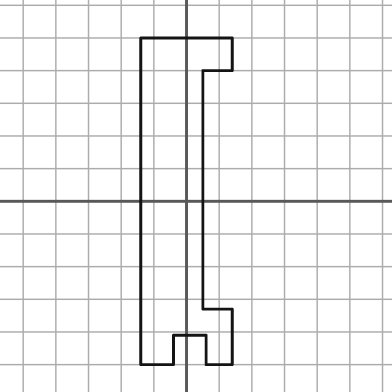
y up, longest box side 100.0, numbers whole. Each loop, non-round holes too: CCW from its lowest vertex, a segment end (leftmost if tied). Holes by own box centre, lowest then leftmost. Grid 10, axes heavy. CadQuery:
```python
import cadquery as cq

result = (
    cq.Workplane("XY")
    .moveTo(-14.0, -50.0)
    .lineTo(-4.0, -50.0)
    .lineTo(-4.0, -41.0)
    .lineTo(6.0, -41.0)
    .lineTo(6.0, -50.0)
    .lineTo(14.0, -50.0)
    .lineTo(14.0, -33.0)
    .lineTo(5.0, -33.0)
    .lineTo(5.0, 40.0)
    .lineTo(14.0, 40.0)
    .lineTo(14.0, 50.0)
    .lineTo(-14.0, 50.0)
    .close()
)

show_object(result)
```